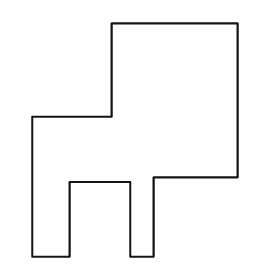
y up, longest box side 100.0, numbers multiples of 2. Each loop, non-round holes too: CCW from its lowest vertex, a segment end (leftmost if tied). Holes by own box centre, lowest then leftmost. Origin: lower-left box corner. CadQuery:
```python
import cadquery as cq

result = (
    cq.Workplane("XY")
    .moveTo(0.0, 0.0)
    .lineTo(16.0, 0.0)
    .lineTo(16.0, 32.0)
    .lineTo(42.0, 32.0)
    .lineTo(42.0, 0.0)
    .lineTo(52.0, 0.0)
    .lineTo(52.0, 34.0)
    .lineTo(88.0, 34.0)
    .lineTo(88.0, 100.0)
    .lineTo(34.0, 100.0)
    .lineTo(34.0, 60.0)
    .lineTo(0.0, 60.0)
    .close()
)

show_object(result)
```